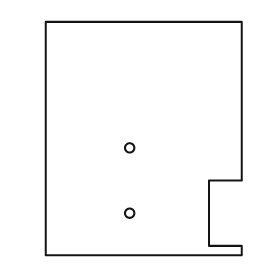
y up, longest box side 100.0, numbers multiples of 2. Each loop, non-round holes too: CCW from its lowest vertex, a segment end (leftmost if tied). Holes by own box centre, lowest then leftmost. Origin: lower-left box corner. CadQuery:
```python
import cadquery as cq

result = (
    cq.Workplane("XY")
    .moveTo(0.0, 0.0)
    .lineTo(84.0, 0.0)
    .lineTo(84.0, 4.0)
    .lineTo(70.0, 4.0)
    .lineTo(70.0, 32.0)
    .lineTo(84.0, 32.0)
    .lineTo(84.0, 100.0)
    .lineTo(0.0, 100.0)
    .close()
    .moveTo(36.0, 18.0)
    .circle(2.0)
    .moveTo(36.0, 46.0)
    .circle(2.0)
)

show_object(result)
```